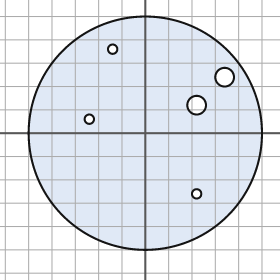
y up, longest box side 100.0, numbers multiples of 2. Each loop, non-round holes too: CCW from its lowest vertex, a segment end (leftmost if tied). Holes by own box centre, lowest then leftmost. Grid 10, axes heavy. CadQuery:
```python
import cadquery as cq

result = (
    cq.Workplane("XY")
    .moveTo(0.0, 0.0)
    .circle(50.0)
    .moveTo(22.0, -26.0)
    .circle(2.0)
    .moveTo(-24.0, 6.0)
    .circle(2.0)
    .moveTo(22.0, 12.0)
    .circle(4.0)
    .moveTo(34.0, 24.0)
    .circle(4.0)
    .moveTo(-14.0, 36.0)
    .circle(2.0)
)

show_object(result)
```